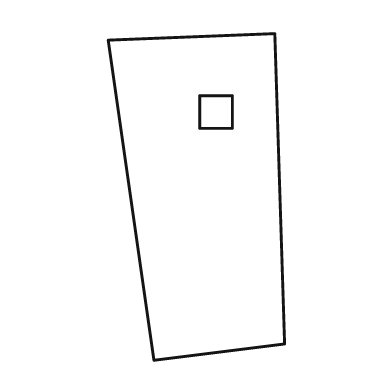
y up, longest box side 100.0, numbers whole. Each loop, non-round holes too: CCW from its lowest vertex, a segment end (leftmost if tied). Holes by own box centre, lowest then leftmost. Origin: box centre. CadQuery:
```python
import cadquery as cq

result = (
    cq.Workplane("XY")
    .moveTo(-13.0, -50.0)
    .lineTo(27.0, -45.0)
    .lineTo(24.0, 50.0)
    .lineTo(-27.0, 48.0)
    .close()
    .moveTo(1.0, 21.0)
    .lineTo(11.0, 21.0)
    .lineTo(11.0, 31.0)
    .lineTo(1.0, 31.0)
    .close()
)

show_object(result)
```